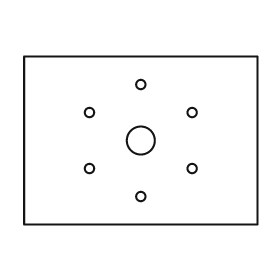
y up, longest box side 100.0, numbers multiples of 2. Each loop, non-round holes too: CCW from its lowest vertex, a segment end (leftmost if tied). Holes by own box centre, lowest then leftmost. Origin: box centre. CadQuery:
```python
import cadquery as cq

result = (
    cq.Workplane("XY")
    .moveTo(-50.0, -36.0)
    .lineTo(50.0, -36.0)
    .lineTo(50.0, 36.0)
    .lineTo(-50.0, 36.0)
    .close()
    .moveTo(0.0, -24.0)
    .circle(2.0)
    .moveTo(-22.0, -12.0)
    .circle(2.0)
    .moveTo(22.0, -12.0)
    .circle(2.0)
    .moveTo(0.0, 0.0)
    .circle(6.0)
    .moveTo(-22.0, 12.0)
    .circle(2.0)
    .moveTo(22.0, 12.0)
    .circle(2.0)
    .moveTo(0.0, 24.0)
    .circle(2.0)
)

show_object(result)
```